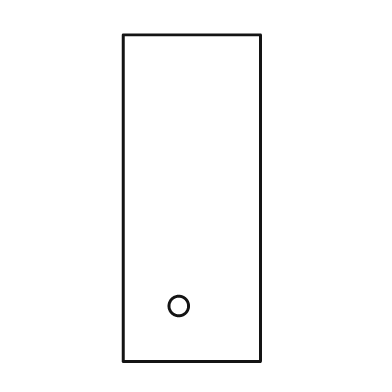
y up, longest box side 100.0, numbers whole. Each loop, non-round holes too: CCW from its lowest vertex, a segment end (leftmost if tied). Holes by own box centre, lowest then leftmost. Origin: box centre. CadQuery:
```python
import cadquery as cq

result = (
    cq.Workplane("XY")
    .moveTo(-21.0, -50.0)
    .lineTo(21.0, -50.0)
    .lineTo(21.0, 50.0)
    .lineTo(-21.0, 50.0)
    .close()
    .moveTo(-4.0, -33.0)
    .circle(3.0)
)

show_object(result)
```